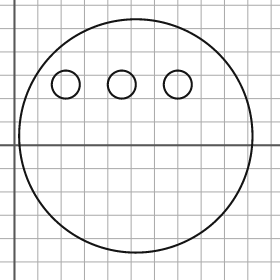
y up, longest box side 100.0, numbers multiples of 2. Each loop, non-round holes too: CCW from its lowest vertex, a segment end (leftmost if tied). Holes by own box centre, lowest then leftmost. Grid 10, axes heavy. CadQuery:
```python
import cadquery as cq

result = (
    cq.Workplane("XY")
    .moveTo(52.0, 4.0)
    .circle(50.0)
    .moveTo(22.0, 26.0)
    .circle(6.0)
    .moveTo(46.0, 26.0)
    .circle(6.0)
    .moveTo(70.0, 26.0)
    .circle(6.0)
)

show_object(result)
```